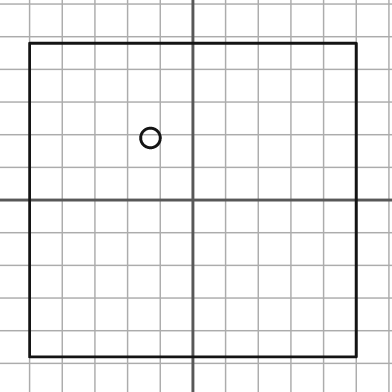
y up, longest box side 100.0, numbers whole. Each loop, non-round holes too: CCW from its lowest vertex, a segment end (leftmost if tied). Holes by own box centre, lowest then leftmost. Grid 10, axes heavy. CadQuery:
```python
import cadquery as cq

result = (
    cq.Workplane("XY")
    .moveTo(-50.0, -48.0)
    .lineTo(50.0, -48.0)
    .lineTo(50.0, 48.0)
    .lineTo(-50.0, 48.0)
    .close()
    .moveTo(-13.0, 19.0)
    .circle(3.0)
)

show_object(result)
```